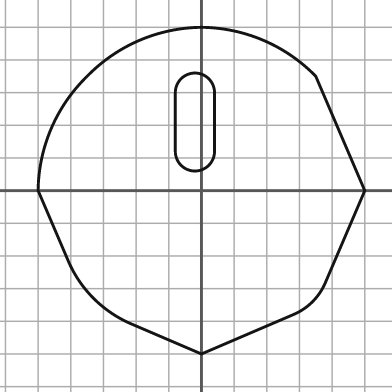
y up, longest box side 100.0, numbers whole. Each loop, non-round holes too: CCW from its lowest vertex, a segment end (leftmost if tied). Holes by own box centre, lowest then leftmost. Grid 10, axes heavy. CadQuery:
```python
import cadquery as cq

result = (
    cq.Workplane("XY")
    .moveTo(0.0, -50.0)
    .lineTo(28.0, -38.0)
    .threePointArc((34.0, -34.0), (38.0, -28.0))
    .lineTo(50.0, 0.0)
    .lineTo(35.0, 35.0)
    .threePointArc((19.0, 46.0), (0.0, 50.0))
    .threePointArc((-19.0, 46.0), (-35.0, 35.0))
    .threePointArc((-46.0, 19.0), (-50.0, 0.0))
    .lineTo(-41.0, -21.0)
    .threePointArc((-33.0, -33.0), (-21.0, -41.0))
    .close()
    .moveTo(-8.0, 12.0)
    .threePointArc((-2.0, 6.0), (4.0, 12.0))
    .lineTo(4.0, 30.0)
    .threePointArc((-2.0, 36.0), (-8.0, 30.0))
    .close()
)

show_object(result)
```